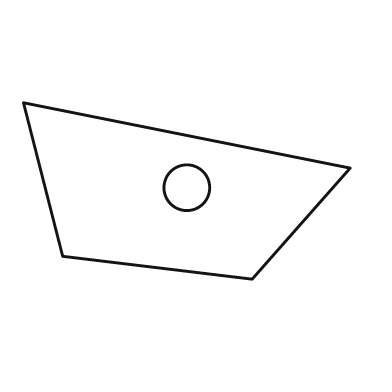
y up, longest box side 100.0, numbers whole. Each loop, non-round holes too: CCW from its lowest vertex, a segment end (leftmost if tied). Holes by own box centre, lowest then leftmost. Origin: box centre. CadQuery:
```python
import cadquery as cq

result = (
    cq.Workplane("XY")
    .moveTo(20.0, -27.0)
    .lineTo(50.0, 7.0)
    .lineTo(-50.0, 27.0)
    .lineTo(-38.0, -20.0)
    .close()
    .moveTo(0.0, 1.0)
    .circle(7.0)
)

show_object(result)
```